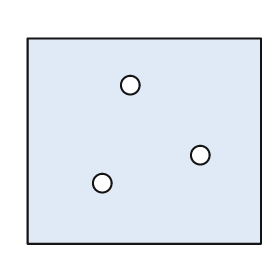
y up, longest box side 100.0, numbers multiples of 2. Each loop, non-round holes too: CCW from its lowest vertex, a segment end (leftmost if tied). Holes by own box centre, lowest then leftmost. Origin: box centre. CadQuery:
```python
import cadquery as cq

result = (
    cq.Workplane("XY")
    .moveTo(-50.0, -44.0)
    .lineTo(50.0, -44.0)
    .lineTo(50.0, 44.0)
    .lineTo(-50.0, 44.0)
    .close()
    .moveTo(-18.0, -18.0)
    .circle(4.0)
    .moveTo(24.0, -6.0)
    .circle(4.0)
    .moveTo(-6.0, 24.0)
    .circle(4.0)
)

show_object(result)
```